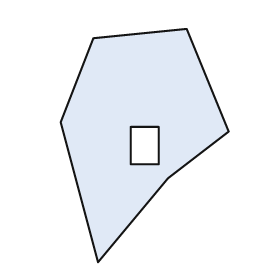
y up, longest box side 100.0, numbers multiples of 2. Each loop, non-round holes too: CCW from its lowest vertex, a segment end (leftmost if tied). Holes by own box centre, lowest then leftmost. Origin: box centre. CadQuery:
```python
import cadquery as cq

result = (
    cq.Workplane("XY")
    .moveTo(-20.0, -50.0)
    .lineTo(10.0, -14.0)
    .lineTo(36.0, 6.0)
    .lineTo(18.0, 50.0)
    .lineTo(-22.0, 46.0)
    .lineTo(-36.0, 10.0)
    .close()
    .moveTo(-6.0, -8.0)
    .lineTo(6.0, -8.0)
    .lineTo(6.0, 8.0)
    .lineTo(-6.0, 8.0)
    .close()
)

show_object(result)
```